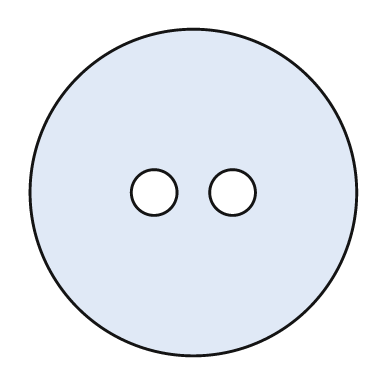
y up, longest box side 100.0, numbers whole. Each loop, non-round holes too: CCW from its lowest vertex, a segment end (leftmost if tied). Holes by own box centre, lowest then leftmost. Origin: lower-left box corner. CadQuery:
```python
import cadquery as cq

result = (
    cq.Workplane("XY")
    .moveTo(50.0, 50.0)
    .circle(50.0)
    .moveTo(38.0, 50.0)
    .circle(7.0)
    .moveTo(62.0, 50.0)
    .circle(7.0)
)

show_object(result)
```